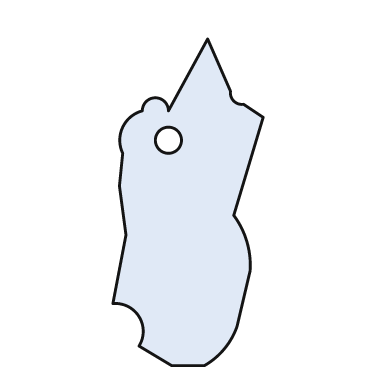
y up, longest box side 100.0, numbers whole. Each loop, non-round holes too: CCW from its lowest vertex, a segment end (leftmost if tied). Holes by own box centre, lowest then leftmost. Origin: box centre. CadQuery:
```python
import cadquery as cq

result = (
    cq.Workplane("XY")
    .moveTo(-5.0, -50.0)
    .lineTo(5.0, -50.0)
    .threePointArc((11.0, -45.0), (15.0, -38.0))
    .lineTo(19.0, -21.0)
    .threePointArc((18.0, -12.0), (14.0, -4.0))
    .lineTo(23.0, 26.0)
    .lineTo(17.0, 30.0)
    .threePointArc((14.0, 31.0), (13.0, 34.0))
    .lineTo(6.0, 50.0)
    .lineTo(-6.0, 28.0)
    .threePointArc((-10.0, 32.0), (-14.0, 28.0))
    .threePointArc((-20.0, 23.0), (-20.0, 15.0))
    .lineTo(-21.0, 5.0)
    .lineTo(-19.0, -10.0)
    .lineTo(-23.0, -31.0)
    .threePointArc((-15.0, -35.0), (-15.0, -44.0))
    .close()
    .moveTo(-6.0, 19.0)
    .circle(4.0)
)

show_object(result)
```